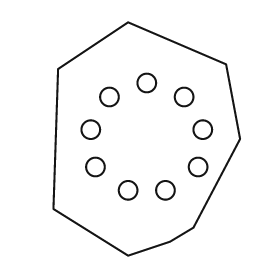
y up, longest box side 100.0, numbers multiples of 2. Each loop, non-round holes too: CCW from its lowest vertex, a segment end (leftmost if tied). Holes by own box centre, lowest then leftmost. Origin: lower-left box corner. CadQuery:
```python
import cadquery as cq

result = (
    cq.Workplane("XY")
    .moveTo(32.0, 0.0)
    .lineTo(50.0, 6.0)
    .lineTo(60.0, 12.0)
    .lineTo(80.0, 50.0)
    .lineTo(74.0, 82.0)
    .lineTo(32.0, 100.0)
    .lineTo(2.0, 80.0)
    .lineTo(0.0, 20.0)
    .close()
    .moveTo(32.0, 28.0)
    .circle(4.0)
    .moveTo(48.0, 28.0)
    .circle(4.0)
    .moveTo(18.0, 38.0)
    .circle(4.0)
    .moveTo(62.0, 38.0)
    .circle(4.0)
    .moveTo(16.0, 54.0)
    .circle(4.0)
    .moveTo(64.0, 54.0)
    .circle(4.0)
    .moveTo(24.0, 68.0)
    .circle(4.0)
    .moveTo(56.0, 68.0)
    .circle(4.0)
    .moveTo(40.0, 74.0)
    .circle(4.0)
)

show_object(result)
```